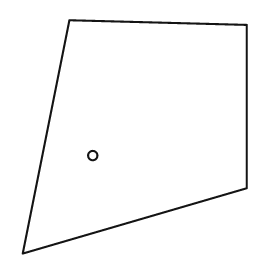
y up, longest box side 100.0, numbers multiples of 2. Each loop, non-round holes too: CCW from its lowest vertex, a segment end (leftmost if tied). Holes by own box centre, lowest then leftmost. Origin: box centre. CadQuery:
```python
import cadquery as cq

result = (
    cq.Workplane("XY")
    .moveTo(-48.0, -50.0)
    .lineTo(48.0, -22.0)
    .lineTo(48.0, 48.0)
    .lineTo(-28.0, 50.0)
    .close()
    .moveTo(-18.0, -8.0)
    .circle(2.0)
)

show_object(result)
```